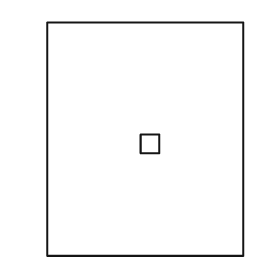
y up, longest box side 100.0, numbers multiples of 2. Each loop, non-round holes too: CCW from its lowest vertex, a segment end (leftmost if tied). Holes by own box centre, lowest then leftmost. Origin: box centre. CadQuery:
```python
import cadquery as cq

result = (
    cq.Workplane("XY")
    .moveTo(-42.0, -50.0)
    .lineTo(42.0, -50.0)
    .lineTo(42.0, 50.0)
    .lineTo(-42.0, 50.0)
    .close()
    .moveTo(-2.0, -6.0)
    .lineTo(6.0, -6.0)
    .lineTo(6.0, 2.0)
    .lineTo(-2.0, 2.0)
    .close()
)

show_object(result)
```